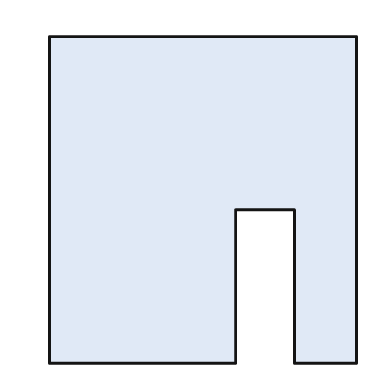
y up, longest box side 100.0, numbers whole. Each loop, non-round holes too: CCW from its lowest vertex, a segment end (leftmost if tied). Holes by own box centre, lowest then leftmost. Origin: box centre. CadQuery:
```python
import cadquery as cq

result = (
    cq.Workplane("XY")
    .moveTo(-47.0, -50.0)
    .lineTo(10.0, -50.0)
    .lineTo(10.0, -3.0)
    .lineTo(28.0, -3.0)
    .lineTo(28.0, -50.0)
    .lineTo(47.0, -50.0)
    .lineTo(47.0, 50.0)
    .lineTo(-47.0, 50.0)
    .close()
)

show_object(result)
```